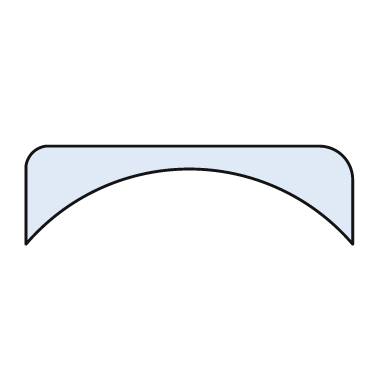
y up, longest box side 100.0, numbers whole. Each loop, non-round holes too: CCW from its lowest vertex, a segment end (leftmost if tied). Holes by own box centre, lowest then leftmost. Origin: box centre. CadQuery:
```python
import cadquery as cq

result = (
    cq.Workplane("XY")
    .moveTo(-50.0, -15.0)
    .threePointArc((0.0, 8.0), (50.0, -15.0))
    .lineTo(50.0, 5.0)
    .threePointArc((47.0, 12.0), (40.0, 15.0))
    .lineTo(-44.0, 15.0)
    .threePointArc((-48.0, 13.0), (-50.0, 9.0))
    .close()
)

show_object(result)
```